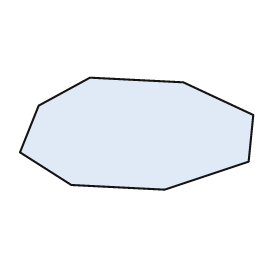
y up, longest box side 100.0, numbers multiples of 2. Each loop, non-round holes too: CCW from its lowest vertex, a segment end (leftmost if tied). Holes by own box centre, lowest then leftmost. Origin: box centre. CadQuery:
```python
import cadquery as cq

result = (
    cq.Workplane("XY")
    .moveTo(12.0, -24.0)
    .lineTo(48.0, -12.0)
    .lineTo(50.0, 8.0)
    .lineTo(20.0, 22.0)
    .lineTo(-20.0, 24.0)
    .lineTo(-42.0, 12.0)
    .lineTo(-50.0, -8.0)
    .lineTo(-28.0, -22.0)
    .close()
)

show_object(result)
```